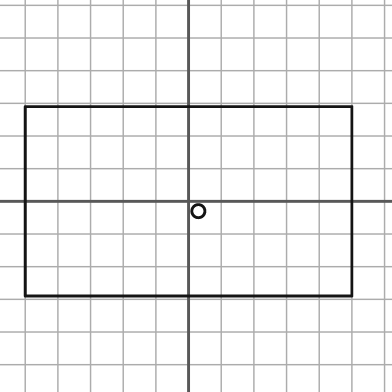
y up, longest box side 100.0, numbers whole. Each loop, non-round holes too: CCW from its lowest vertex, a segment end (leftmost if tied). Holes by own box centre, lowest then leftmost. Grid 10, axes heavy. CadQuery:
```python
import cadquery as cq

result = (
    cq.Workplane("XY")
    .moveTo(-50.0, -29.0)
    .lineTo(50.0, -29.0)
    .lineTo(50.0, 29.0)
    .lineTo(-50.0, 29.0)
    .close()
    .moveTo(3.0, -3.0)
    .circle(2.0)
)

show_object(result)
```